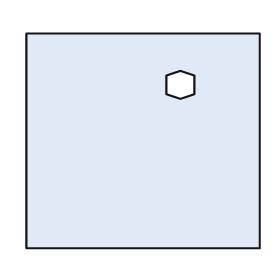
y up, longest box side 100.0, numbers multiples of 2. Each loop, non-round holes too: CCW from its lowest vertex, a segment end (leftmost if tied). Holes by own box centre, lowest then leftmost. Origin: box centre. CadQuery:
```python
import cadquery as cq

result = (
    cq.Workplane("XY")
    .moveTo(-50.0, -46.0)
    .lineTo(50.0, -46.0)
    .lineTo(50.0, 46.0)
    .lineTo(-50.0, 46.0)
    .close()
    .moveTo(16.0, 18.0)
    .lineTo(22.0, 20.0)
    .lineTo(22.0, 28.0)
    .lineTo(16.0, 30.0)
    .lineTo(10.0, 28.0)
    .lineTo(10.0, 20.0)
    .close()
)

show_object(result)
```